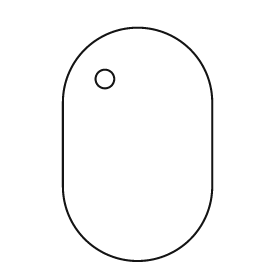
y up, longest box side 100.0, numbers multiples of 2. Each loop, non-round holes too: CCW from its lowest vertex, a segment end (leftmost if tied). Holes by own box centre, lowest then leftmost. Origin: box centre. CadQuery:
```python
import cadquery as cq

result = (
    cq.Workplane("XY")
    .moveTo(-32.0, -18.0)
    .threePointArc((0.0, -50.0), (32.0, -18.0))
    .lineTo(32.0, 18.0)
    .threePointArc((0.0, 50.0), (-32.0, 18.0))
    .close()
    .moveTo(-14.0, 28.0)
    .circle(4.0)
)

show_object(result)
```